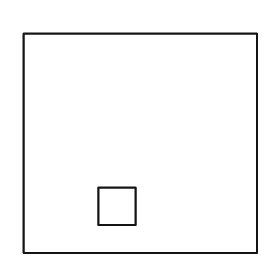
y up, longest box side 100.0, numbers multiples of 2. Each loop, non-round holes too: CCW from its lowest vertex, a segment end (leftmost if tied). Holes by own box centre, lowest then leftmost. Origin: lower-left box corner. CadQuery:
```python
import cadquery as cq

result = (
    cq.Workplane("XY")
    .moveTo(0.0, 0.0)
    .lineTo(100.0, 0.0)
    .lineTo(100.0, 94.0)
    .lineTo(0.0, 94.0)
    .close()
    .moveTo(32.0, 12.0)
    .lineTo(48.0, 12.0)
    .lineTo(48.0, 28.0)
    .lineTo(32.0, 28.0)
    .close()
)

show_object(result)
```